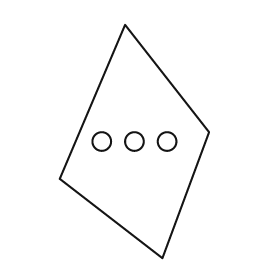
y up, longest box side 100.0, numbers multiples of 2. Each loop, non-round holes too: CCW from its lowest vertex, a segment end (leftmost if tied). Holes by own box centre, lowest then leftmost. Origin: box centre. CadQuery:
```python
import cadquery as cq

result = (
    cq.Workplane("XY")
    .moveTo(12.0, -50.0)
    .lineTo(32.0, 4.0)
    .lineTo(-4.0, 50.0)
    .lineTo(-32.0, -16.0)
    .close()
    .moveTo(-14.0, 0.0)
    .circle(4.0)
    .moveTo(0.0, 0.0)
    .circle(4.0)
    .moveTo(14.0, 0.0)
    .circle(4.0)
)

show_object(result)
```